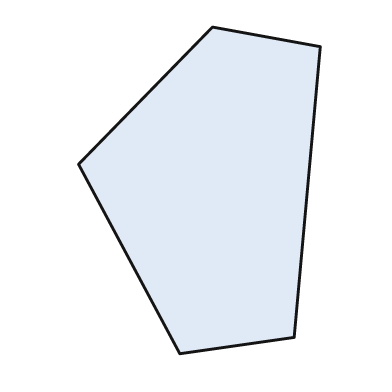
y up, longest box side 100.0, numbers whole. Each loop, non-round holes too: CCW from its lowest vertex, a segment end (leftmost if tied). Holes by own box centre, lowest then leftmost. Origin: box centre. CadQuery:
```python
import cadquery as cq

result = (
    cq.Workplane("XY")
    .moveTo(-6.0, -50.0)
    .lineTo(29.0, -45.0)
    .lineTo(37.0, 44.0)
    .lineTo(4.0, 50.0)
    .lineTo(-37.0, 8.0)
    .close()
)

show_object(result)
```